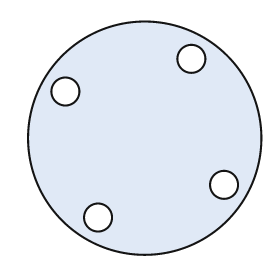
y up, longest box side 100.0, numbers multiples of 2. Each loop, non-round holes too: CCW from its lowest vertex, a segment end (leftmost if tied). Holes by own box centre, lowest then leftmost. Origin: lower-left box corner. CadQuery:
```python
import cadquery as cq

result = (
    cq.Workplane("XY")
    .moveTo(50.0, 50.0)
    .circle(50.0)
    .moveTo(30.0, 16.0)
    .circle(6.0)
    .moveTo(84.0, 30.0)
    .circle(6.0)
    .moveTo(16.0, 70.0)
    .circle(6.0)
    .moveTo(70.0, 84.0)
    .circle(6.0)
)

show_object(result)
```